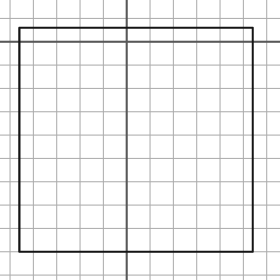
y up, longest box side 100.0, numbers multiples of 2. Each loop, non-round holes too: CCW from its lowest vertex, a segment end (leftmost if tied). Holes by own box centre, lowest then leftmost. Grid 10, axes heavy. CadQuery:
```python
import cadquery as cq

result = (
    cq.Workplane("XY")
    .moveTo(-46.0, -90.0)
    .lineTo(54.0, -90.0)
    .lineTo(54.0, 6.0)
    .lineTo(-46.0, 6.0)
    .close()
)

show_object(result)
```